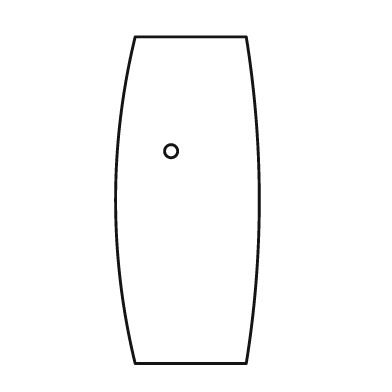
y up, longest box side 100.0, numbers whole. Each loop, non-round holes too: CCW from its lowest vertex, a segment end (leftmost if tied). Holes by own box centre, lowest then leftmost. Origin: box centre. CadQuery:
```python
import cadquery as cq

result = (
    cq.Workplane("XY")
    .moveTo(-16.0, -50.0)
    .lineTo(18.0, -50.0)
    .threePointArc((22.0, 0.0), (18.0, 50.0))
    .lineTo(-16.0, 50.0)
    .threePointArc((-22.0, 0.0), (-16.0, -50.0))
    .close()
    .moveTo(-5.0, 15.0)
    .circle(2.0)
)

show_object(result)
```